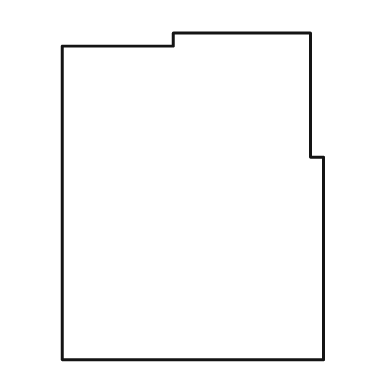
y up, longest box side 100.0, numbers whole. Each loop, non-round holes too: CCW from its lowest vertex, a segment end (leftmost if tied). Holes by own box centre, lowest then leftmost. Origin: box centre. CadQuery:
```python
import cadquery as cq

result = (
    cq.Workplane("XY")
    .moveTo(-40.0, -50.0)
    .lineTo(40.0, -50.0)
    .lineTo(40.0, 12.0)
    .lineTo(36.0, 12.0)
    .lineTo(36.0, 50.0)
    .lineTo(-6.0, 50.0)
    .lineTo(-6.0, 46.0)
    .lineTo(-40.0, 46.0)
    .close()
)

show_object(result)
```